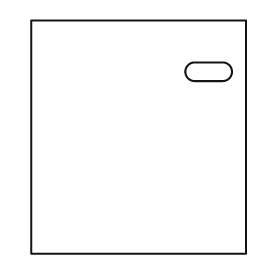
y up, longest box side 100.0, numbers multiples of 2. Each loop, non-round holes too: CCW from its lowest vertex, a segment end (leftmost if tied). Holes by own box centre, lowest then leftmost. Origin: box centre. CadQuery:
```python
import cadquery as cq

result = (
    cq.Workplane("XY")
    .moveTo(-46.0, -50.0)
    .lineTo(46.0, -50.0)
    .lineTo(46.0, 50.0)
    .lineTo(-46.0, 50.0)
    .close()
    .moveTo(24.0, 24.0)
    .lineTo(36.0, 24.0)
    .threePointArc((40.0, 28.0), (36.0, 32.0))
    .lineTo(24.0, 32.0)
    .threePointArc((20.0, 28.0), (24.0, 24.0))
    .close()
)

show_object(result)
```